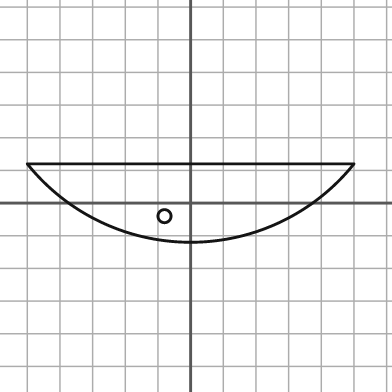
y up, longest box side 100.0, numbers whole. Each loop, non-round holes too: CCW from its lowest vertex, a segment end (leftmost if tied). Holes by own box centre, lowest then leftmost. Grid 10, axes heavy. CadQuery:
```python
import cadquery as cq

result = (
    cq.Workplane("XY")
    .moveTo(-50.0, 12.0)
    .threePointArc((0.0, -12.0), (50.0, 12.0))
    .close()
    .moveTo(-8.0, -4.0)
    .circle(2.0)
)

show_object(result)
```